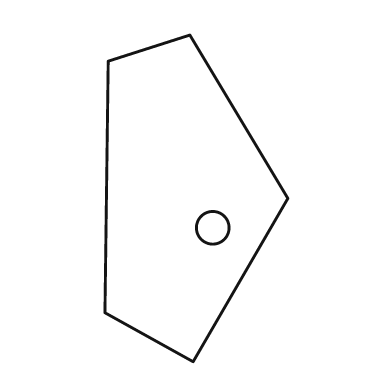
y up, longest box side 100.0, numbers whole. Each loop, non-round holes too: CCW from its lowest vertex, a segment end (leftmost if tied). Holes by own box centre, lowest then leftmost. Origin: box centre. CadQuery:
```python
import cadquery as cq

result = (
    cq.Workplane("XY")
    .moveTo(-1.0, -50.0)
    .lineTo(28.0, 0.0)
    .lineTo(-2.0, 50.0)
    .lineTo(-27.0, 42.0)
    .lineTo(-28.0, -35.0)
    .close()
    .moveTo(5.0, -9.0)
    .circle(5.0)
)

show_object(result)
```